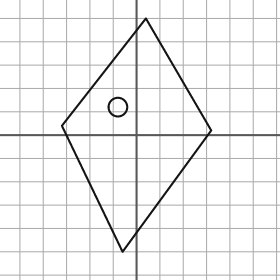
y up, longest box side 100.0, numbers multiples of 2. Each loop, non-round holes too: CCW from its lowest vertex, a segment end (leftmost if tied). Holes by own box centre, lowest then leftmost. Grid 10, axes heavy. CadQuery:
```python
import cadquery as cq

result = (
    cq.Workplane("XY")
    .moveTo(-6.0, -50.0)
    .lineTo(32.0, 2.0)
    .lineTo(4.0, 50.0)
    .lineTo(-32.0, 4.0)
    .close()
    .moveTo(-8.0, 12.0)
    .circle(4.0)
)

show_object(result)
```